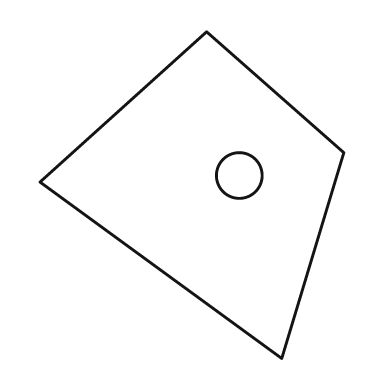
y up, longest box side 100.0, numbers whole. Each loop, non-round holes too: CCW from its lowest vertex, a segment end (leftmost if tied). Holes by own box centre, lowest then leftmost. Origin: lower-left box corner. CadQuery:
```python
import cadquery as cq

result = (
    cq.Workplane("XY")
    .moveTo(74.0, 0.0)
    .lineTo(93.0, 63.0)
    .lineTo(51.0, 100.0)
    .lineTo(0.0, 54.0)
    .close()
    .moveTo(61.0, 56.0)
    .circle(7.0)
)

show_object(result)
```